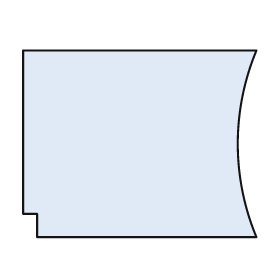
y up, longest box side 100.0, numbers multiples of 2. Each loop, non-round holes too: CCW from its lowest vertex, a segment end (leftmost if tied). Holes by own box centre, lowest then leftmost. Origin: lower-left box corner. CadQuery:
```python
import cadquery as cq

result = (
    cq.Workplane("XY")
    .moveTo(6.0, 0.0)
    .lineTo(100.0, 0.0)
    .threePointArc((92.0, 40.0), (100.0, 80.0))
    .lineTo(0.0, 80.0)
    .lineTo(0.0, 10.0)
    .lineTo(6.0, 10.0)
    .close()
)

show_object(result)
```